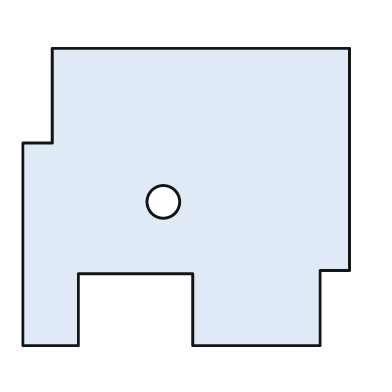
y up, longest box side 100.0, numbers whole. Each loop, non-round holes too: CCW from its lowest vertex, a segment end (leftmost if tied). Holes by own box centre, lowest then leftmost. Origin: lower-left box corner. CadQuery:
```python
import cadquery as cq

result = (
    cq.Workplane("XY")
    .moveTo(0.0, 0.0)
    .lineTo(17.0, 0.0)
    .lineTo(17.0, 22.0)
    .lineTo(52.0, 22.0)
    .lineTo(52.0, 0.0)
    .lineTo(91.0, 0.0)
    .lineTo(91.0, 23.0)
    .lineTo(100.0, 23.0)
    .lineTo(100.0, 91.0)
    .lineTo(9.0, 91.0)
    .lineTo(9.0, 62.0)
    .lineTo(0.0, 62.0)
    .close()
    .moveTo(43.0, 44.0)
    .circle(5.0)
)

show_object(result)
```